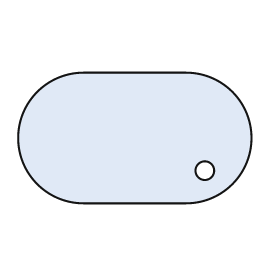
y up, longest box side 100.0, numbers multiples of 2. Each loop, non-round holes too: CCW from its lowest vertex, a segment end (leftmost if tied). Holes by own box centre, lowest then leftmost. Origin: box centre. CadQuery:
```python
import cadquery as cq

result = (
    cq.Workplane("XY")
    .moveTo(-22.0, -28.0)
    .lineTo(22.0, -28.0)
    .threePointArc((50.0, 0.0), (22.0, 28.0))
    .lineTo(-22.0, 28.0)
    .threePointArc((-50.0, 0.0), (-22.0, -28.0))
    .close()
    .moveTo(30.0, -14.0)
    .circle(4.0)
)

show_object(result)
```